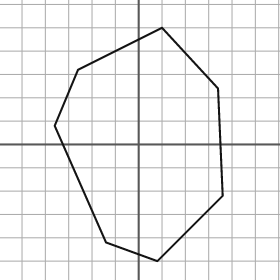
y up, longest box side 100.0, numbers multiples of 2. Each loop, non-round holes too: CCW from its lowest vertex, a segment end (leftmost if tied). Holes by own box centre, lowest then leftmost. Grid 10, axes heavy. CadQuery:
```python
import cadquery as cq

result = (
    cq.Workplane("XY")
    .moveTo(8.0, -50.0)
    .lineTo(36.0, -22.0)
    .lineTo(34.0, 24.0)
    .lineTo(10.0, 50.0)
    .lineTo(-26.0, 32.0)
    .lineTo(-36.0, 8.0)
    .lineTo(-14.0, -42.0)
    .close()
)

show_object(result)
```